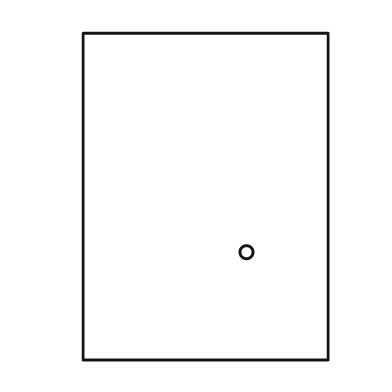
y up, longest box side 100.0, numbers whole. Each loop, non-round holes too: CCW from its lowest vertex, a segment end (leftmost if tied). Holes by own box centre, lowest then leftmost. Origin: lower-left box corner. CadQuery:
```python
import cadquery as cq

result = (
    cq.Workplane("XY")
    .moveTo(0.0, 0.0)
    .lineTo(75.0, 0.0)
    .lineTo(75.0, 100.0)
    .lineTo(0.0, 100.0)
    .close()
    .moveTo(50.0, 33.0)
    .circle(2.0)
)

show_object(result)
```